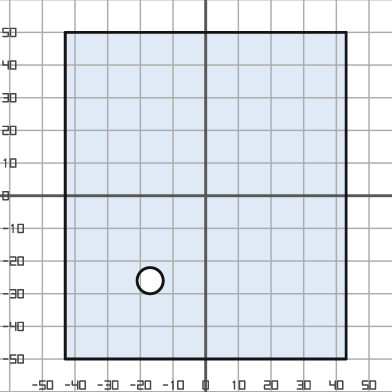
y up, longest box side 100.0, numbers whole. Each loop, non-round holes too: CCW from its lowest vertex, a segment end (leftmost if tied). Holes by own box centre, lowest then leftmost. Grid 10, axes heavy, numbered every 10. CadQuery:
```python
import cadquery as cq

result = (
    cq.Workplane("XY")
    .moveTo(-43.0, -50.0)
    .lineTo(43.0, -50.0)
    .lineTo(43.0, 50.0)
    .lineTo(-43.0, 50.0)
    .close()
    .moveTo(-17.0, -26.0)
    .circle(4.0)
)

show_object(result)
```